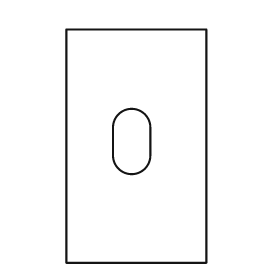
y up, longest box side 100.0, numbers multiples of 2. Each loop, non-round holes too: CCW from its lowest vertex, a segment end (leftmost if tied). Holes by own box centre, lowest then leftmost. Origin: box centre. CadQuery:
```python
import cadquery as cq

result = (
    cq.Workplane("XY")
    .moveTo(-30.0, -50.0)
    .lineTo(30.0, -50.0)
    .lineTo(30.0, 50.0)
    .lineTo(-30.0, 50.0)
    .close()
    .moveTo(-10.0, -4.0)
    .threePointArc((-2.0, -12.0), (6.0, -4.0))
    .lineTo(6.0, 8.0)
    .threePointArc((-2.0, 16.0), (-10.0, 8.0))
    .close()
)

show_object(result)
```